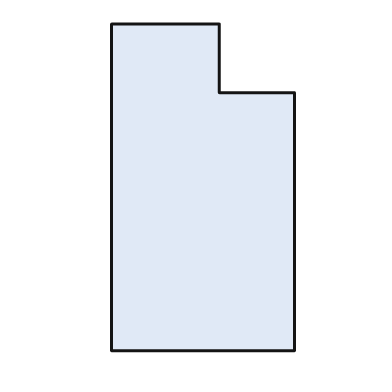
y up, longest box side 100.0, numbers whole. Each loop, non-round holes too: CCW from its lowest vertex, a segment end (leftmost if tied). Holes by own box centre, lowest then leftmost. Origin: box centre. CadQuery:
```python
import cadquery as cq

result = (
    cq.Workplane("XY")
    .moveTo(-28.0, -50.0)
    .lineTo(28.0, -50.0)
    .lineTo(28.0, 29.0)
    .lineTo(5.0, 29.0)
    .lineTo(5.0, 50.0)
    .lineTo(-28.0, 50.0)
    .close()
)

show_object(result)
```